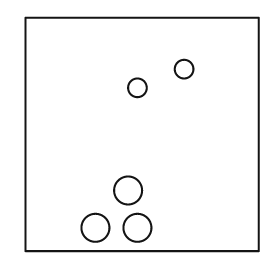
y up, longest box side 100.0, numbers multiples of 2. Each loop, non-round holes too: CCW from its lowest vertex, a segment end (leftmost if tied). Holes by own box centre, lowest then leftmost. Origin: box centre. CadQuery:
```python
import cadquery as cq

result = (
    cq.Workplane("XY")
    .moveTo(-50.0, -50.0)
    .lineTo(50.0, -50.0)
    .lineTo(50.0, 50.0)
    .lineTo(-50.0, 50.0)
    .close()
    .moveTo(-20.0, -40.0)
    .circle(6.0)
    .moveTo(-2.0, -40.0)
    .circle(6.0)
    .moveTo(-6.0, -24.0)
    .circle(6.0)
    .moveTo(-2.0, 20.0)
    .circle(4.0)
    .moveTo(18.0, 28.0)
    .circle(4.0)
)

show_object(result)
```